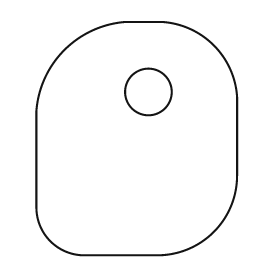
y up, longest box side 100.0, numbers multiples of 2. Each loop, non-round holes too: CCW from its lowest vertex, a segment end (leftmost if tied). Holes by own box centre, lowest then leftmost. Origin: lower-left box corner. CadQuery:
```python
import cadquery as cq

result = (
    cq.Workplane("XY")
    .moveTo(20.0, 0.0)
    .lineTo(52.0, 0.0)
    .threePointArc((76.0, 10.0), (86.0, 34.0))
    .lineTo(86.0, 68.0)
    .threePointArc((76.0, 90.0), (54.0, 100.0))
    .lineTo(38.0, 100.0)
    .threePointArc((12.0, 88.0), (0.0, 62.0))
    .lineTo(0.0, 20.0)
    .threePointArc((6.0, 6.0), (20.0, 0.0))
    .close()
    .moveTo(48.0, 70.0)
    .circle(10.0)
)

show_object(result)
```